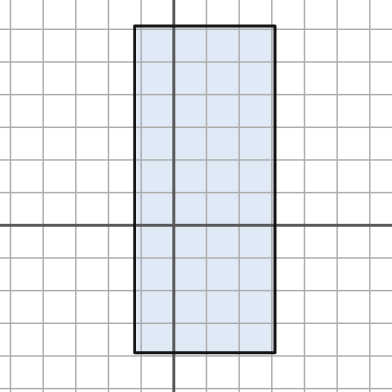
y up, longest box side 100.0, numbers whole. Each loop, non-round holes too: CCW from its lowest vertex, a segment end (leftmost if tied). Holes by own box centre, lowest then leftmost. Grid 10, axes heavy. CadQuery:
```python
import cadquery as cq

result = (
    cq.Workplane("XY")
    .moveTo(-12.0, -39.0)
    .lineTo(31.0, -39.0)
    .lineTo(31.0, 61.0)
    .lineTo(-12.0, 61.0)
    .close()
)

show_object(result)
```